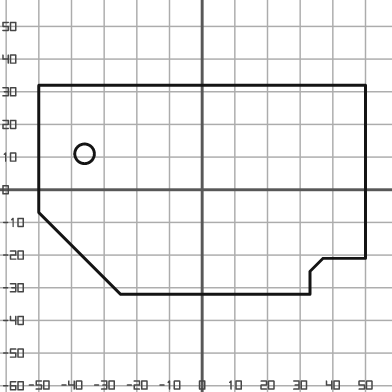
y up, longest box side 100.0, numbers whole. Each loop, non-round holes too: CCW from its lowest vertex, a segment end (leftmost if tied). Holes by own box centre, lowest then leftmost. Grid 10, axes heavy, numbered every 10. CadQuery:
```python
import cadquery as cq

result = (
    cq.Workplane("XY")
    .moveTo(-25.0, -32.0)
    .lineTo(33.0, -32.0)
    .lineTo(33.0, -25.0)
    .lineTo(37.0, -21.0)
    .lineTo(50.0, -21.0)
    .lineTo(50.0, 32.0)
    .lineTo(-50.0, 32.0)
    .lineTo(-50.0, -7.0)
    .close()
    .moveTo(-36.0, 11.0)
    .circle(3.0)
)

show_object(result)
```